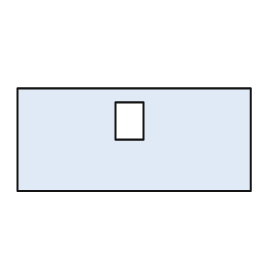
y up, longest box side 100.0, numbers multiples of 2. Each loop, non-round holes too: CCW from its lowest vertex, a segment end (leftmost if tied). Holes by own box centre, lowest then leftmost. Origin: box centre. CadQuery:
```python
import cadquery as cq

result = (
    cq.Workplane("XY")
    .moveTo(-50.0, -22.0)
    .lineTo(50.0, -22.0)
    .lineTo(50.0, 22.0)
    .lineTo(-50.0, 22.0)
    .close()
    .moveTo(-8.0, 0.0)
    .lineTo(4.0, 0.0)
    .lineTo(4.0, 16.0)
    .lineTo(-8.0, 16.0)
    .close()
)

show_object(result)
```